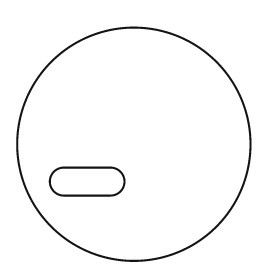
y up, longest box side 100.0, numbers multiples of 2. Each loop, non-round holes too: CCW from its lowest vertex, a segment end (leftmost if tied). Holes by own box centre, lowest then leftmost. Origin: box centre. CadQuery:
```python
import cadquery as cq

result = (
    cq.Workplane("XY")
    .moveTo(0.0, 0.0)
    .circle(50.0)
    .moveTo(-30.0, -22.0)
    .lineTo(-10.0, -22.0)
    .threePointArc((-4.0, -16.0), (-10.0, -10.0))
    .lineTo(-30.0, -10.0)
    .threePointArc((-36.0, -16.0), (-30.0, -22.0))
    .close()
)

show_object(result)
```